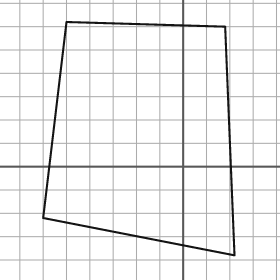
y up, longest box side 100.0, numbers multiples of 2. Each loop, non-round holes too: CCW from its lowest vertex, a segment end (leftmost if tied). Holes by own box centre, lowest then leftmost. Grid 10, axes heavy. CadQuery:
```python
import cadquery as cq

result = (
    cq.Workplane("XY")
    .moveTo(22.0, -38.0)
    .lineTo(18.0, 60.0)
    .lineTo(-50.0, 62.0)
    .lineTo(-60.0, -22.0)
    .close()
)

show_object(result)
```